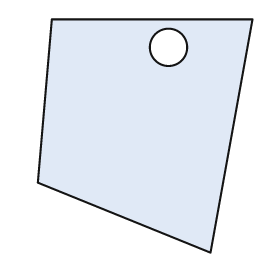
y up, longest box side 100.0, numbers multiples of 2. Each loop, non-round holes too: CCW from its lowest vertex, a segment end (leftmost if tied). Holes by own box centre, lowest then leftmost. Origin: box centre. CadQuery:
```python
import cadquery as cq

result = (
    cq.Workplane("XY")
    .moveTo(28.0, -50.0)
    .lineTo(46.0, 50.0)
    .lineTo(-40.0, 50.0)
    .lineTo(-46.0, -20.0)
    .close()
    .moveTo(10.0, 38.0)
    .circle(8.0)
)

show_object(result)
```